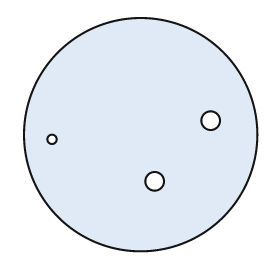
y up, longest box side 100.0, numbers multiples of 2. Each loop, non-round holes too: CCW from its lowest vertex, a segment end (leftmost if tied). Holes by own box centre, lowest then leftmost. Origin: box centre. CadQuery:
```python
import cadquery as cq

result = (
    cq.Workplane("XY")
    .moveTo(0.0, 0.0)
    .circle(50.0)
    .moveTo(6.0, -20.0)
    .circle(4.0)
    .moveTo(-38.0, -2.0)
    .circle(2.0)
    .moveTo(30.0, 6.0)
    .circle(4.0)
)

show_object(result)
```